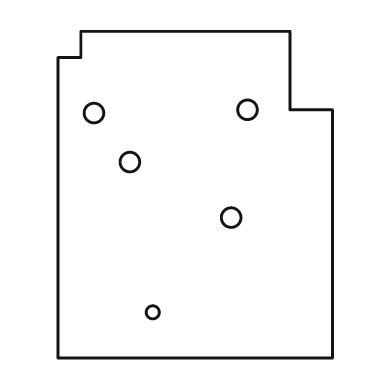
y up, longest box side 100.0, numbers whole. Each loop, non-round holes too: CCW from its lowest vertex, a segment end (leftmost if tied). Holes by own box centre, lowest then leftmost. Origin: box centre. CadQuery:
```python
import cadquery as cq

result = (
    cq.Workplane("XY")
    .moveTo(-42.0, -50.0)
    .lineTo(42.0, -50.0)
    .lineTo(42.0, 26.0)
    .lineTo(29.0, 26.0)
    .lineTo(29.0, 50.0)
    .lineTo(-35.0, 50.0)
    .lineTo(-35.0, 42.0)
    .lineTo(-42.0, 42.0)
    .close()
    .moveTo(-13.0, -36.0)
    .circle(2.0)
    .moveTo(11.0, -7.0)
    .circle(3.0)
    .moveTo(-20.0, 10.0)
    .circle(3.0)
    .moveTo(-31.0, 25.0)
    .circle(3.0)
    .moveTo(16.0, 26.0)
    .circle(3.0)
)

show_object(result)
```